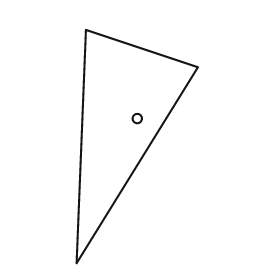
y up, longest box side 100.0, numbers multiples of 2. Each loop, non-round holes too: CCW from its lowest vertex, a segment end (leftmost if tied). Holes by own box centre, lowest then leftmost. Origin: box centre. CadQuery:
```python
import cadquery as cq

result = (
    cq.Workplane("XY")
    .moveTo(-26.0, -50.0)
    .lineTo(26.0, 34.0)
    .lineTo(-22.0, 50.0)
    .close()
    .moveTo(0.0, 12.0)
    .circle(2.0)
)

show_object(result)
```